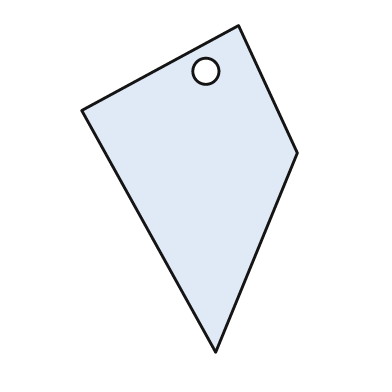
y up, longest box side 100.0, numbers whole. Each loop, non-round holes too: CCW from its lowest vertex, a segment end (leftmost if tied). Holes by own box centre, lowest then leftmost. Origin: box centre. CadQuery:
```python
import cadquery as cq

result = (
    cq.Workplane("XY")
    .moveTo(8.0, -50.0)
    .lineTo(33.0, 11.0)
    .lineTo(15.0, 50.0)
    .lineTo(-33.0, 24.0)
    .close()
    .moveTo(5.0, 36.0)
    .circle(4.0)
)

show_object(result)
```